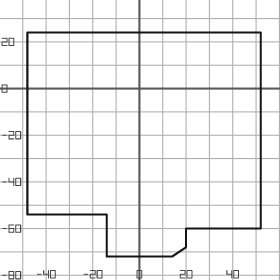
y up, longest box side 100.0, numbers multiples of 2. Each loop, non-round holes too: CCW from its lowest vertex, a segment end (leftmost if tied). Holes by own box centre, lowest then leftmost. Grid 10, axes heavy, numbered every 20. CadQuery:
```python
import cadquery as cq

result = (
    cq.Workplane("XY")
    .moveTo(-14.0, -72.0)
    .lineTo(14.0, -72.0)
    .lineTo(20.0, -68.0)
    .lineTo(20.0, -60.0)
    .lineTo(52.0, -60.0)
    .lineTo(52.0, 24.0)
    .lineTo(-48.0, 24.0)
    .lineTo(-48.0, -54.0)
    .lineTo(-14.0, -54.0)
    .close()
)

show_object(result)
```